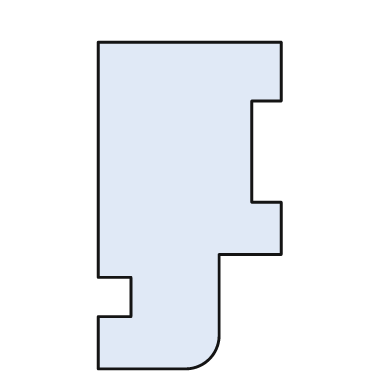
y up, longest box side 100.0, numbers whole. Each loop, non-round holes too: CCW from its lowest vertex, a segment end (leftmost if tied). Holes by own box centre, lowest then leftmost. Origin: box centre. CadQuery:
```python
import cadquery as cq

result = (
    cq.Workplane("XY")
    .moveTo(-28.0, -50.0)
    .lineTo(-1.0, -50.0)
    .threePointArc((6.0, -47.0), (9.0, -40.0))
    .lineTo(9.0, -15.0)
    .lineTo(28.0, -15.0)
    .lineTo(28.0, 1.0)
    .lineTo(19.0, 1.0)
    .lineTo(19.0, 32.0)
    .lineTo(28.0, 32.0)
    .lineTo(28.0, 50.0)
    .lineTo(-28.0, 50.0)
    .lineTo(-28.0, -22.0)
    .lineTo(-18.0, -22.0)
    .lineTo(-18.0, -34.0)
    .lineTo(-28.0, -34.0)
    .close()
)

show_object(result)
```